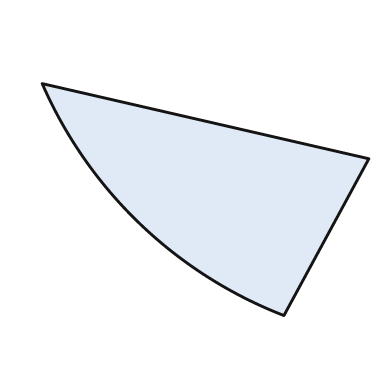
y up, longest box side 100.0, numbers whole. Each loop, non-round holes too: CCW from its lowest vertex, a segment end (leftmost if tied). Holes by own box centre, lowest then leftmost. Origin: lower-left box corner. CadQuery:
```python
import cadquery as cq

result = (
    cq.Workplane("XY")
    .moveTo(74.0, 0.0)
    .lineTo(100.0, 48.0)
    .lineTo(0.0, 71.0)
    .threePointArc((30.0, 28.0), (74.0, 0.0))
    .close()
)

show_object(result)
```